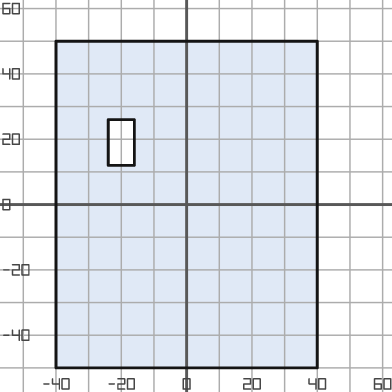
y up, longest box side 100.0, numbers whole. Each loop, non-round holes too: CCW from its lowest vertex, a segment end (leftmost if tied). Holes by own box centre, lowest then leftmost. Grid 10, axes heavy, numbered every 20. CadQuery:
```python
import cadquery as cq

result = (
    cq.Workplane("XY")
    .moveTo(-40.0, -50.0)
    .lineTo(40.0, -50.0)
    .lineTo(40.0, 50.0)
    .lineTo(-40.0, 50.0)
    .close()
    .moveTo(-24.0, 12.0)
    .lineTo(-16.0, 12.0)
    .lineTo(-16.0, 26.0)
    .lineTo(-24.0, 26.0)
    .close()
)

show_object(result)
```